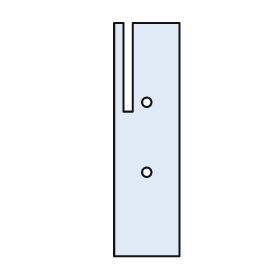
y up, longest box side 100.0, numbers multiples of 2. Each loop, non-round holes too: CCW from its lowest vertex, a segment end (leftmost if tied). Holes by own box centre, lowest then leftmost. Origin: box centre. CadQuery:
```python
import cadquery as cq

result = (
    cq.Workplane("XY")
    .moveTo(-14.0, -50.0)
    .lineTo(14.0, -50.0)
    .lineTo(14.0, 50.0)
    .lineTo(-6.0, 50.0)
    .lineTo(-6.0, 12.0)
    .lineTo(-10.0, 12.0)
    .lineTo(-10.0, 50.0)
    .lineTo(-14.0, 50.0)
    .close()
    .moveTo(0.0, -14.0)
    .circle(2.0)
    .moveTo(0.0, 16.0)
    .circle(2.0)
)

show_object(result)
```